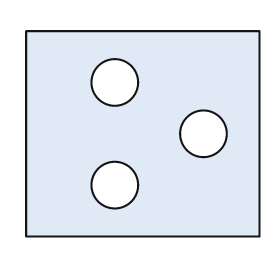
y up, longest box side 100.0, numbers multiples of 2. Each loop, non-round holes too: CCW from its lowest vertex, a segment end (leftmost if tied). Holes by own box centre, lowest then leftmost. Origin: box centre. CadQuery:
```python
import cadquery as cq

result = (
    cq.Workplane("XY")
    .moveTo(-50.0, -44.0)
    .lineTo(50.0, -44.0)
    .lineTo(50.0, 44.0)
    .lineTo(-50.0, 44.0)
    .close()
    .moveTo(-12.0, -22.0)
    .circle(10.0)
    .moveTo(26.0, 0.0)
    .circle(10.0)
    .moveTo(-12.0, 22.0)
    .circle(10.0)
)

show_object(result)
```